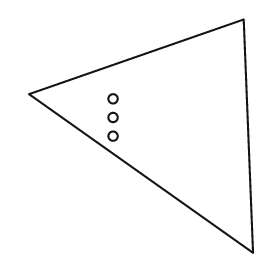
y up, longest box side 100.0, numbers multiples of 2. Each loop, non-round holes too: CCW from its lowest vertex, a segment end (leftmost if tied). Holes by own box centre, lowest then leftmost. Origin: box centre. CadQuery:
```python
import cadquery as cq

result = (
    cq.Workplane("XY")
    .moveTo(48.0, -50.0)
    .lineTo(44.0, 50.0)
    .lineTo(-48.0, 18.0)
    .close()
    .moveTo(-12.0, 0.0)
    .circle(2.0)
    .moveTo(-12.0, 8.0)
    .circle(2.0)
    .moveTo(-12.0, 16.0)
    .circle(2.0)
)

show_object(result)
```